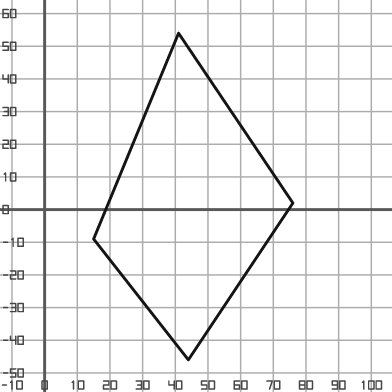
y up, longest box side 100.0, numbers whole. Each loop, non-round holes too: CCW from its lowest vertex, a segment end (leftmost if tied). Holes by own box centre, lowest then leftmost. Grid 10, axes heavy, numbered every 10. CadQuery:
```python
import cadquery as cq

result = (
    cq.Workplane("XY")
    .moveTo(44.0, -46.0)
    .lineTo(76.0, 2.0)
    .lineTo(41.0, 54.0)
    .lineTo(15.0, -9.0)
    .close()
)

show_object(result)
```